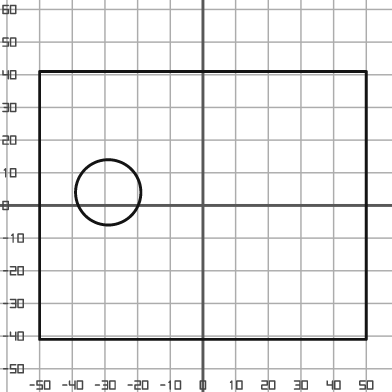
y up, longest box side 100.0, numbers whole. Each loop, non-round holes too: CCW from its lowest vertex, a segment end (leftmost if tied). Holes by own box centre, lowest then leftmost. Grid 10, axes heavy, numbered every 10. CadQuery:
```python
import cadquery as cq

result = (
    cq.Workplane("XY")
    .moveTo(-50.0, -41.0)
    .lineTo(50.0, -41.0)
    .lineTo(50.0, 41.0)
    .lineTo(-50.0, 41.0)
    .close()
    .moveTo(-29.0, 4.0)
    .circle(10.0)
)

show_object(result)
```